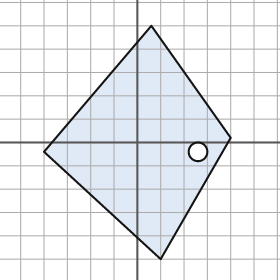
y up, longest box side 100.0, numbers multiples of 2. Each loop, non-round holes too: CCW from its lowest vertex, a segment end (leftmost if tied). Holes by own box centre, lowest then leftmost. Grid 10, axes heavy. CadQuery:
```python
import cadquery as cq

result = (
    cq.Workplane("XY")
    .moveTo(10.0, -50.0)
    .lineTo(40.0, 2.0)
    .lineTo(6.0, 50.0)
    .lineTo(-40.0, -4.0)
    .close()
    .moveTo(26.0, -4.0)
    .circle(4.0)
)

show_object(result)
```